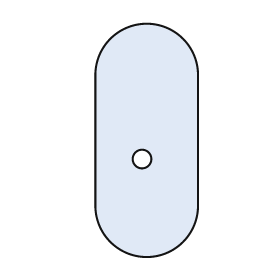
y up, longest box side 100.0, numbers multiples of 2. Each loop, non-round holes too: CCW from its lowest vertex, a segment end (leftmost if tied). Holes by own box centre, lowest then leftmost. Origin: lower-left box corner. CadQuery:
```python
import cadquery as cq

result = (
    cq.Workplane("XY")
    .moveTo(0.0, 22.0)
    .threePointArc((22.0, 0.0), (44.0, 22.0))
    .lineTo(44.0, 78.0)
    .threePointArc((22.0, 100.0), (0.0, 78.0))
    .close()
    .moveTo(20.0, 42.0)
    .circle(4.0)
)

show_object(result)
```